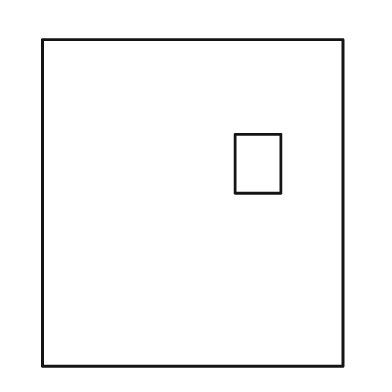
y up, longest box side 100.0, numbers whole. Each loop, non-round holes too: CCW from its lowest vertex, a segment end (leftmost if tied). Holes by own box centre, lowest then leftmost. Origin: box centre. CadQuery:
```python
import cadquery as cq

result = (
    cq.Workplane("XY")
    .moveTo(-46.0, -50.0)
    .lineTo(46.0, -50.0)
    .lineTo(46.0, 50.0)
    .lineTo(-46.0, 50.0)
    .close()
    .moveTo(13.0, 3.0)
    .lineTo(27.0, 3.0)
    .lineTo(27.0, 21.0)
    .lineTo(13.0, 21.0)
    .close()
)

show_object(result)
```